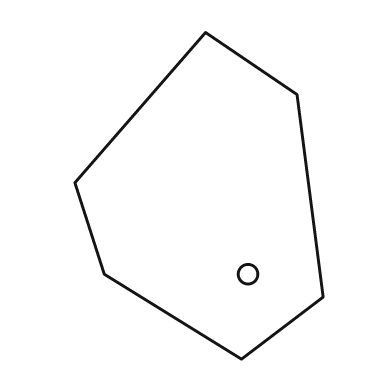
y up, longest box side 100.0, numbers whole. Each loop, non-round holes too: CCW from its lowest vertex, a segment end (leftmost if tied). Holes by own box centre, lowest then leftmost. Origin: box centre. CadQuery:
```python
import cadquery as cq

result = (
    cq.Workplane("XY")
    .moveTo(13.0, -50.0)
    .lineTo(38.0, -31.0)
    .lineTo(30.0, 31.0)
    .lineTo(2.0, 50.0)
    .lineTo(-38.0, 4.0)
    .lineTo(-29.0, -24.0)
    .close()
    .moveTo(15.0, -24.0)
    .circle(3.0)
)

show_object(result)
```